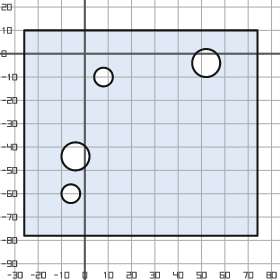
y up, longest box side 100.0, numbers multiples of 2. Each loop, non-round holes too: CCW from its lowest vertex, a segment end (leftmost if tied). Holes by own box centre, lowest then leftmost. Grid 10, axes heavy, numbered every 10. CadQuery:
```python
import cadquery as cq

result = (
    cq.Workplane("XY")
    .moveTo(-26.0, -78.0)
    .lineTo(74.0, -78.0)
    .lineTo(74.0, 10.0)
    .lineTo(-26.0, 10.0)
    .close()
    .moveTo(-6.0, -60.0)
    .circle(4.0)
    .moveTo(-4.0, -44.0)
    .circle(6.0)
    .moveTo(8.0, -10.0)
    .circle(4.0)
    .moveTo(52.0, -4.0)
    .circle(6.0)
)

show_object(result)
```